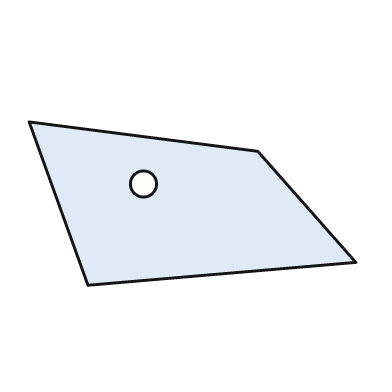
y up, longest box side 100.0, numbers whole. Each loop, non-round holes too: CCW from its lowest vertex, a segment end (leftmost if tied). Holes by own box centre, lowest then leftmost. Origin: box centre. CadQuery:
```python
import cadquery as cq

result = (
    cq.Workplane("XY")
    .moveTo(-32.0, -25.0)
    .lineTo(50.0, -18.0)
    .lineTo(20.0, 16.0)
    .lineTo(-50.0, 25.0)
    .close()
    .moveTo(-15.0, 6.0)
    .circle(4.0)
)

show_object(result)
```